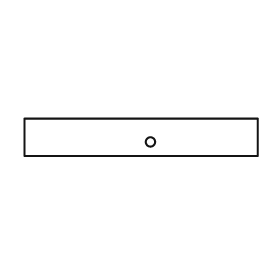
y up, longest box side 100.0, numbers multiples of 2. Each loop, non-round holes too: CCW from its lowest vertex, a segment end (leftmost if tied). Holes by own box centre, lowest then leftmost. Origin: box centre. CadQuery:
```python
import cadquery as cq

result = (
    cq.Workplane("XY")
    .moveTo(-50.0, -8.0)
    .lineTo(50.0, -8.0)
    .lineTo(50.0, 8.0)
    .lineTo(-50.0, 8.0)
    .close()
    .moveTo(4.0, -2.0)
    .circle(2.0)
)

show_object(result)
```